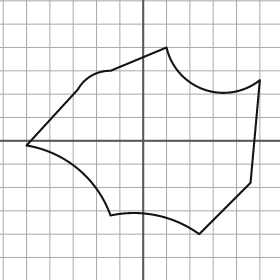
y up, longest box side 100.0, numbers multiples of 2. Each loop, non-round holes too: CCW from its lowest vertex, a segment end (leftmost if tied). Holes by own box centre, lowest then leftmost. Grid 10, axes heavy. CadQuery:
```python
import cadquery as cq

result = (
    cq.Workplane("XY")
    .moveTo(24.0, -40.0)
    .lineTo(46.0, -18.0)
    .lineTo(50.0, 26.0)
    .threePointArc((26.0, 22.0), (10.0, 40.0))
    .lineTo(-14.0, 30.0)
    .threePointArc((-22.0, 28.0), (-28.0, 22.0))
    .lineTo(-50.0, -2.0)
    .threePointArc((-28.0, -12.0), (-14.0, -32.0))
    .threePointArc((6.0, -32.0), (24.0, -40.0))
    .close()
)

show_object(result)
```